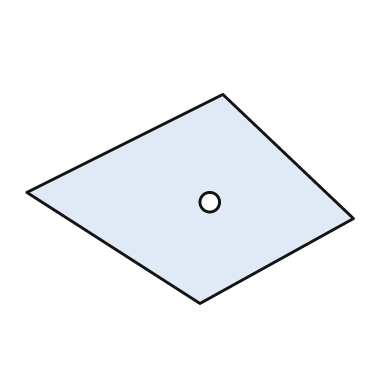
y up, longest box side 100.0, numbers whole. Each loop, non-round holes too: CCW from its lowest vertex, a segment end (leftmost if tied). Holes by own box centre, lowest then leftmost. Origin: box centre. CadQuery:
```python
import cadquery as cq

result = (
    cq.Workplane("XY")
    .moveTo(3.0, -32.0)
    .lineTo(50.0, -6.0)
    .lineTo(10.0, 32.0)
    .lineTo(-50.0, 2.0)
    .close()
    .moveTo(6.0, -1.0)
    .circle(3.0)
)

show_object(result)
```